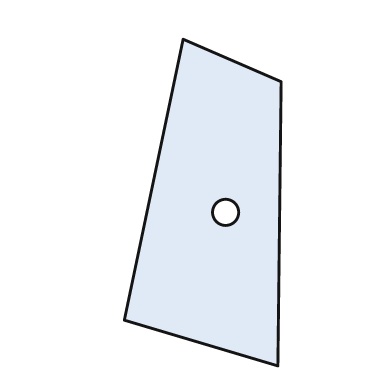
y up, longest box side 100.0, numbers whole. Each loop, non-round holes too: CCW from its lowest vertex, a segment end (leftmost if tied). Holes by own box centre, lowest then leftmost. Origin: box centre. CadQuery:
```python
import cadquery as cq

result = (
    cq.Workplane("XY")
    .moveTo(23.0, -50.0)
    .lineTo(24.0, 37.0)
    .lineTo(-6.0, 50.0)
    .lineTo(-24.0, -36.0)
    .close()
    .moveTo(7.0, -3.0)
    .circle(4.0)
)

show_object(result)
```